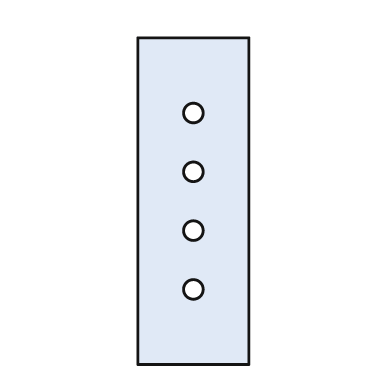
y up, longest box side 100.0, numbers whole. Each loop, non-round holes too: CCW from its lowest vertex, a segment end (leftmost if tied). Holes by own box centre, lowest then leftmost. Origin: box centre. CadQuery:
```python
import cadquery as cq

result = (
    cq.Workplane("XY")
    .moveTo(-17.0, -50.0)
    .lineTo(17.0, -50.0)
    .lineTo(17.0, 50.0)
    .lineTo(-17.0, 50.0)
    .close()
    .moveTo(0.0, -27.0)
    .circle(3.0)
    .moveTo(0.0, -9.0)
    .circle(3.0)
    .moveTo(0.0, 9.0)
    .circle(3.0)
    .moveTo(0.0, 27.0)
    .circle(3.0)
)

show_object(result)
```